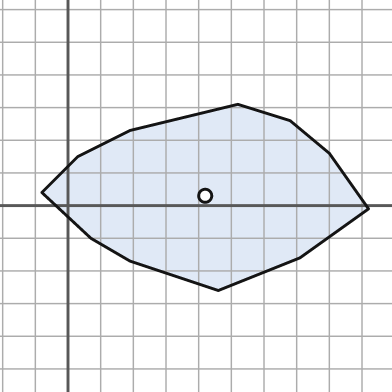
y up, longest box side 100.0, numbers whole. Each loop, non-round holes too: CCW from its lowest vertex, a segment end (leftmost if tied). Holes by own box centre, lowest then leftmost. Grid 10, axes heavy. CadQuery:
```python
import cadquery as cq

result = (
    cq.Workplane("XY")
    .moveTo(46.0, -26.0)
    .lineTo(71.0, -16.0)
    .lineTo(92.0, -1.0)
    .lineTo(80.0, 16.0)
    .lineTo(68.0, 26.0)
    .lineTo(52.0, 31.0)
    .lineTo(19.0, 23.0)
    .lineTo(3.0, 15.0)
    .lineTo(-8.0, 4.0)
    .lineTo(7.0, -10.0)
    .lineTo(19.0, -17.0)
    .close()
    .moveTo(42.0, 3.0)
    .circle(2.0)
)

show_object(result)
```